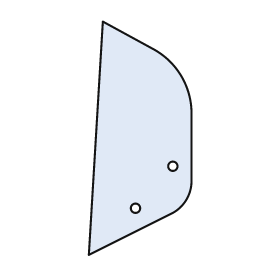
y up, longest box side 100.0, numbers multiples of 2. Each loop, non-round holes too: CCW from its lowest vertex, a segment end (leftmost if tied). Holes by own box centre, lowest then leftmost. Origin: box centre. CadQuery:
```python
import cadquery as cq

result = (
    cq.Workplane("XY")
    .moveTo(-22.0, -50.0)
    .lineTo(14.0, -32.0)
    .threePointArc((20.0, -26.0), (22.0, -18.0))
    .lineTo(22.0, 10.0)
    .threePointArc((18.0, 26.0), (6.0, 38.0))
    .lineTo(-16.0, 50.0)
    .close()
    .moveTo(-2.0, -30.0)
    .circle(2.0)
    .moveTo(14.0, -12.0)
    .circle(2.0)
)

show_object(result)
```